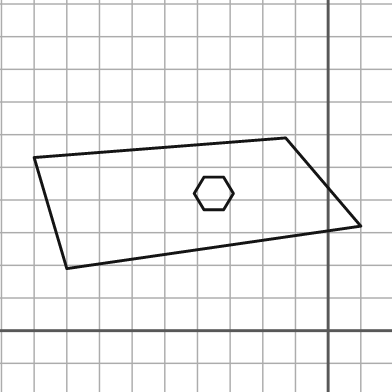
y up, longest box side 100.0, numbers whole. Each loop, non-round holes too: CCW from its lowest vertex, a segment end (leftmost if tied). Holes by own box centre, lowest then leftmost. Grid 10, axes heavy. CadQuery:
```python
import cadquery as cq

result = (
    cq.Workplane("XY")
    .moveTo(-80.0, 19.0)
    .lineTo(10.0, 32.0)
    .lineTo(-13.0, 59.0)
    .lineTo(-90.0, 53.0)
    .close()
    .moveTo(-38.0, 37.0)
    .lineTo(-32.0, 37.0)
    .lineTo(-29.0, 42.0)
    .lineTo(-32.0, 47.0)
    .lineTo(-38.0, 47.0)
    .lineTo(-41.0, 42.0)
    .close()
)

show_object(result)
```